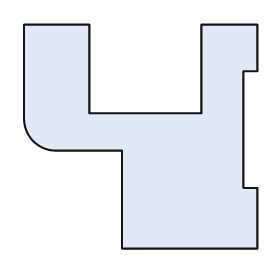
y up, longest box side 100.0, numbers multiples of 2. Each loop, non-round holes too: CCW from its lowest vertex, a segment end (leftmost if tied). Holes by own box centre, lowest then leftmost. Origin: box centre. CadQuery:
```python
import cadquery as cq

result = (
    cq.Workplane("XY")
    .moveTo(-8.0, -48.0)
    .lineTo(50.0, -48.0)
    .lineTo(50.0, -22.0)
    .lineTo(44.0, -22.0)
    .lineTo(44.0, 28.0)
    .lineTo(50.0, 28.0)
    .lineTo(50.0, 48.0)
    .lineTo(26.0, 48.0)
    .lineTo(26.0, 10.0)
    .lineTo(-22.0, 10.0)
    .lineTo(-22.0, 48.0)
    .lineTo(-50.0, 48.0)
    .lineTo(-50.0, 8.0)
    .threePointArc((-46.0, -2.0), (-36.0, -6.0))
    .lineTo(-8.0, -6.0)
    .close()
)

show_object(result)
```